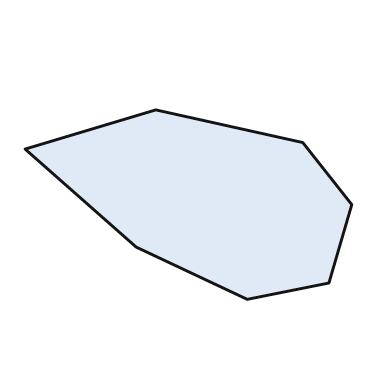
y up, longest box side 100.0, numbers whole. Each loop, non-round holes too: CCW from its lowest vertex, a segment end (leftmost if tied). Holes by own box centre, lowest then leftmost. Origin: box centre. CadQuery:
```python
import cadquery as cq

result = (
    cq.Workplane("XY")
    .moveTo(18.0, -29.0)
    .lineTo(43.0, -24.0)
    .lineTo(50.0, 0.0)
    .lineTo(35.0, 19.0)
    .lineTo(-10.0, 29.0)
    .lineTo(-50.0, 17.0)
    .lineTo(-16.0, -13.0)
    .close()
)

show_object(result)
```